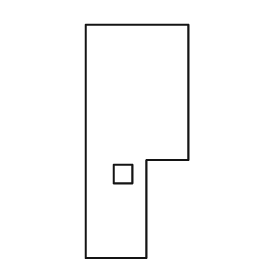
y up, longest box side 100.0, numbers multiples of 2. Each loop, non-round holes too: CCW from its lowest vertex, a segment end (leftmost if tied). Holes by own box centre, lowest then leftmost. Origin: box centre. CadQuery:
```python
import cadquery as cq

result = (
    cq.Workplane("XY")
    .moveTo(-22.0, -50.0)
    .lineTo(4.0, -50.0)
    .lineTo(4.0, -8.0)
    .lineTo(22.0, -8.0)
    .lineTo(22.0, 50.0)
    .lineTo(-22.0, 50.0)
    .close()
    .moveTo(-10.0, -18.0)
    .lineTo(-2.0, -18.0)
    .lineTo(-2.0, -10.0)
    .lineTo(-10.0, -10.0)
    .close()
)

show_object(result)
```